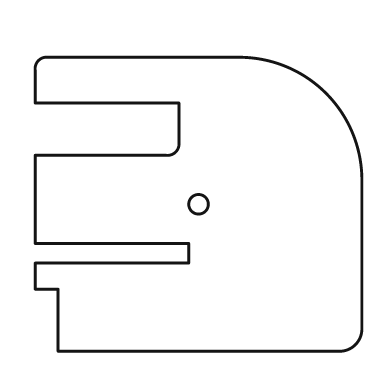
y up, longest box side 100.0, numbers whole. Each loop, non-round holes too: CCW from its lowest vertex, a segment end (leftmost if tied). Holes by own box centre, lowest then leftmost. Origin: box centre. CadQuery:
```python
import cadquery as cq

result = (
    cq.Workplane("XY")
    .moveTo(-43.0, -45.0)
    .lineTo(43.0, -45.0)
    .threePointArc((48.0, -43.0), (50.0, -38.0))
    .lineTo(50.0, 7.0)
    .threePointArc((39.0, 34.0), (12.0, 45.0))
    .lineTo(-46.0, 45.0)
    .threePointArc((-49.0, 44.0), (-50.0, 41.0))
    .lineTo(-50.0, 31.0)
    .lineTo(-6.0, 31.0)
    .lineTo(-6.0, 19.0)
    .threePointArc((-7.0, 16.0), (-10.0, 15.0))
    .lineTo(-50.0, 15.0)
    .lineTo(-50.0, -12.0)
    .lineTo(-3.0, -12.0)
    .lineTo(-3.0, -18.0)
    .lineTo(-50.0, -18.0)
    .lineTo(-50.0, -26.0)
    .lineTo(-43.0, -26.0)
    .close()
    .moveTo(0.0, 0.0)
    .circle(3.0)
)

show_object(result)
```